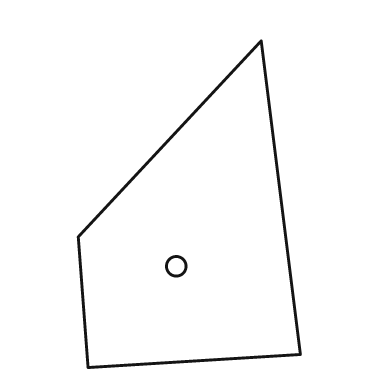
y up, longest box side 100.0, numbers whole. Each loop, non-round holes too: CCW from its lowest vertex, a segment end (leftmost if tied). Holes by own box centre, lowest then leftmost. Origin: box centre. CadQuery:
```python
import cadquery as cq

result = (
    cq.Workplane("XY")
    .moveTo(-31.0, -50.0)
    .lineTo(34.0, -46.0)
    .lineTo(22.0, 50.0)
    .lineTo(-34.0, -10.0)
    .close()
    .moveTo(-4.0, -19.0)
    .circle(3.0)
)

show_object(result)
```